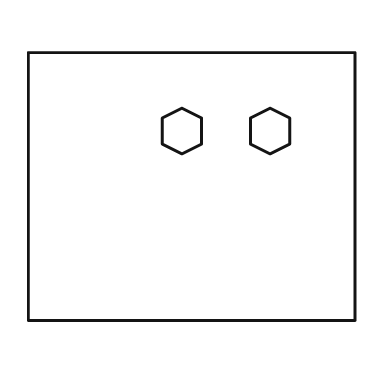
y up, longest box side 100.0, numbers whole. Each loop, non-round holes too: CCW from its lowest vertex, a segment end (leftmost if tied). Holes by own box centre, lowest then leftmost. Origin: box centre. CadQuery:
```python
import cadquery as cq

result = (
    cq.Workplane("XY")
    .moveTo(-50.0, -41.0)
    .lineTo(50.0, -41.0)
    .lineTo(50.0, 41.0)
    .lineTo(-50.0, 41.0)
    .close()
    .moveTo(-3.0, 10.0)
    .lineTo(3.0, 13.0)
    .lineTo(3.0, 21.0)
    .lineTo(-3.0, 24.0)
    .lineTo(-9.0, 21.0)
    .lineTo(-9.0, 13.0)
    .close()
    .moveTo(24.0, 10.0)
    .lineTo(30.0, 13.0)
    .lineTo(30.0, 21.0)
    .lineTo(24.0, 24.0)
    .lineTo(18.0, 21.0)
    .lineTo(18.0, 13.0)
    .close()
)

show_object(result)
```